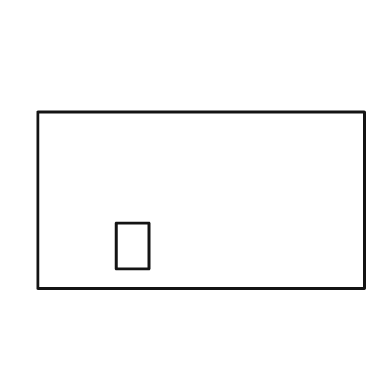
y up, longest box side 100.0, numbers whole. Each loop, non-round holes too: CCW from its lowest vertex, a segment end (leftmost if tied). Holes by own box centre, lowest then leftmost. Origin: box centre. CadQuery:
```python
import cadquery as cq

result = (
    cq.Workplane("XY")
    .moveTo(-50.0, -27.0)
    .lineTo(50.0, -27.0)
    .lineTo(50.0, 27.0)
    .lineTo(-50.0, 27.0)
    .close()
    .moveTo(-26.0, -21.0)
    .lineTo(-16.0, -21.0)
    .lineTo(-16.0, -7.0)
    .lineTo(-26.0, -7.0)
    .close()
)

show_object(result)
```